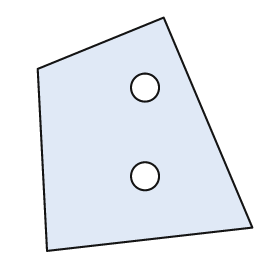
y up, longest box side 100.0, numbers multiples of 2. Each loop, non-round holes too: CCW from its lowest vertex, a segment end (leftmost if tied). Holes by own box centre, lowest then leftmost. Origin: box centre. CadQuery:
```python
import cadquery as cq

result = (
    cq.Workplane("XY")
    .moveTo(-42.0, -50.0)
    .lineTo(46.0, -40.0)
    .lineTo(8.0, 50.0)
    .lineTo(-46.0, 28.0)
    .close()
    .moveTo(0.0, -18.0)
    .circle(6.0)
    .moveTo(0.0, 20.0)
    .circle(6.0)
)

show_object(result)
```